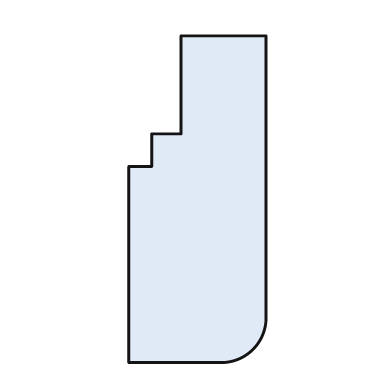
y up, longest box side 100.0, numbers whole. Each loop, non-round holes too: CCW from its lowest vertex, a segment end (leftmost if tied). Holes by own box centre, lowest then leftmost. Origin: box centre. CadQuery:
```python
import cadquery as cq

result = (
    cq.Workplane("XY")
    .moveTo(-21.0, -50.0)
    .lineTo(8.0, -50.0)
    .threePointArc((17.0, -46.0), (21.0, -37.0))
    .lineTo(21.0, 50.0)
    .lineTo(-5.0, 50.0)
    .lineTo(-5.0, 20.0)
    .lineTo(-14.0, 20.0)
    .lineTo(-14.0, 10.0)
    .lineTo(-21.0, 10.0)
    .close()
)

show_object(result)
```